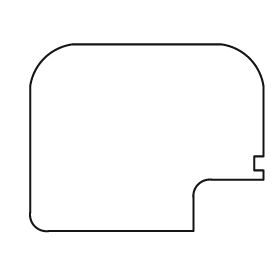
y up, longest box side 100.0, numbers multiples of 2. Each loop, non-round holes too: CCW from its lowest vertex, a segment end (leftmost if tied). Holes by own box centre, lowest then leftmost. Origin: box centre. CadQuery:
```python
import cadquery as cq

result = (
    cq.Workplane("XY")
    .moveTo(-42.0, -40.0)
    .lineTo(20.0, -40.0)
    .lineTo(20.0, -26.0)
    .threePointArc((22.0, -20.0), (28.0, -18.0))
    .lineTo(50.0, -18.0)
    .lineTo(50.0, -14.0)
    .lineTo(46.0, -14.0)
    .lineTo(46.0, -8.0)
    .lineTo(50.0, -8.0)
    .lineTo(50.0, 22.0)
    .threePointArc((44.0, 34.0), (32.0, 40.0))
    .lineTo(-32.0, 40.0)
    .threePointArc((-44.0, 34.0), (-50.0, 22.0))
    .lineTo(-50.0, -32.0)
    .threePointArc((-48.0, -38.0), (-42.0, -40.0))
    .close()
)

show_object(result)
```